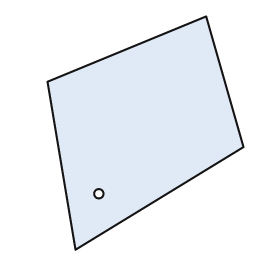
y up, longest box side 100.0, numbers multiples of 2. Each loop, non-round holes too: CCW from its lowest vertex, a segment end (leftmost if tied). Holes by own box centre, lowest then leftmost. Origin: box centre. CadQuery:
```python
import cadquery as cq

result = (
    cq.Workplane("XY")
    .moveTo(-30.0, -50.0)
    .lineTo(42.0, -6.0)
    .lineTo(26.0, 50.0)
    .lineTo(-42.0, 22.0)
    .close()
    .moveTo(-20.0, -26.0)
    .circle(2.0)
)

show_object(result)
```